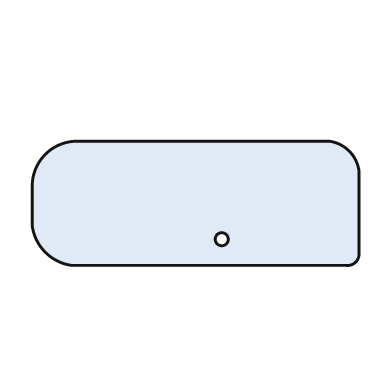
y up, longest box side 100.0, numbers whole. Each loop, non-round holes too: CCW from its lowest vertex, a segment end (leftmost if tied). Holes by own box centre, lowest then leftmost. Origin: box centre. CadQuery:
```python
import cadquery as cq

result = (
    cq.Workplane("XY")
    .moveTo(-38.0, -19.0)
    .lineTo(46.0, -19.0)
    .threePointArc((49.0, -18.0), (50.0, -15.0))
    .lineTo(50.0, 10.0)
    .threePointArc((47.0, 16.0), (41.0, 19.0))
    .lineTo(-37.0, 19.0)
    .threePointArc((-46.0, 15.0), (-50.0, 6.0))
    .lineTo(-50.0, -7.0)
    .threePointArc((-46.0, -15.0), (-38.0, -19.0))
    .close()
    .moveTo(8.0, -11.0)
    .circle(2.0)
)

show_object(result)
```